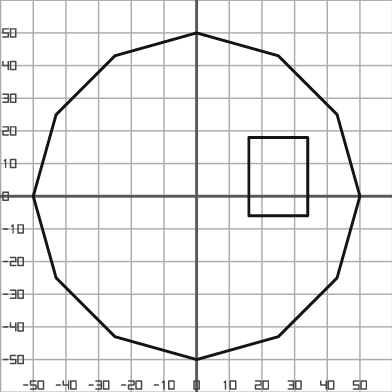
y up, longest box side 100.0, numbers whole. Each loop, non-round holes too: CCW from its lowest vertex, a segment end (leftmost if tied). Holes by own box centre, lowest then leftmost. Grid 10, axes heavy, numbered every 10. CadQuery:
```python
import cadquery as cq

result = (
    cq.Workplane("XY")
    .moveTo(0.0, -50.0)
    .lineTo(25.0, -43.0)
    .lineTo(43.0, -25.0)
    .lineTo(50.0, 0.0)
    .lineTo(43.0, 25.0)
    .lineTo(25.0, 43.0)
    .lineTo(0.0, 50.0)
    .lineTo(-25.0, 43.0)
    .lineTo(-43.0, 25.0)
    .lineTo(-50.0, 0.0)
    .lineTo(-43.0, -25.0)
    .lineTo(-25.0, -43.0)
    .close()
    .moveTo(16.0, -6.0)
    .lineTo(34.0, -6.0)
    .lineTo(34.0, 18.0)
    .lineTo(16.0, 18.0)
    .close()
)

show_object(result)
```